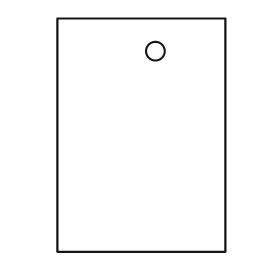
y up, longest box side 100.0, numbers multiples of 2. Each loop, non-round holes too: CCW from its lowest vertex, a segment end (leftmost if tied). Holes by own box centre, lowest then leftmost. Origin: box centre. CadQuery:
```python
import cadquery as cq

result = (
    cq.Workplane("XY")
    .moveTo(-36.0, -50.0)
    .lineTo(36.0, -50.0)
    .lineTo(36.0, 50.0)
    .lineTo(-36.0, 50.0)
    .close()
    .moveTo(6.0, 36.0)
    .circle(4.0)
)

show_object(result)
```